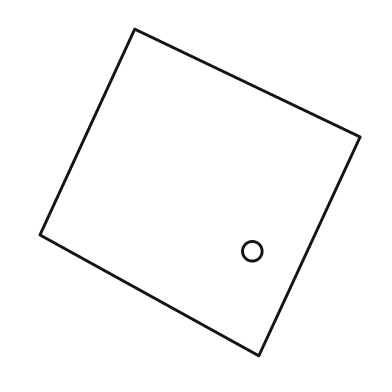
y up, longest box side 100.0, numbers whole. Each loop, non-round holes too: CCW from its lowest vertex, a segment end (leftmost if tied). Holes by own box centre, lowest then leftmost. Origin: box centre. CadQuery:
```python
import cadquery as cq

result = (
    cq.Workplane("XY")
    .moveTo(18.0, -50.0)
    .lineTo(49.0, 17.0)
    .lineTo(-20.0, 50.0)
    .lineTo(-49.0, -13.0)
    .close()
    .moveTo(16.0, -18.0)
    .circle(3.0)
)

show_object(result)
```